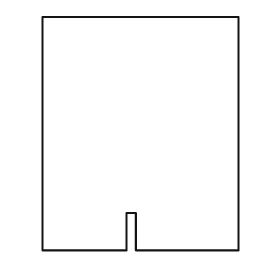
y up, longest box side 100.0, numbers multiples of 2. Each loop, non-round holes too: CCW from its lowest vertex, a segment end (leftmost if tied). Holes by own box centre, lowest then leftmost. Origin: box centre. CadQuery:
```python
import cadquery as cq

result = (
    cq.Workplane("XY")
    .moveTo(-42.0, -50.0)
    .lineTo(-6.0, -50.0)
    .lineTo(-6.0, -34.0)
    .lineTo(-2.0, -34.0)
    .lineTo(-2.0, -50.0)
    .lineTo(42.0, -50.0)
    .lineTo(42.0, 50.0)
    .lineTo(-42.0, 50.0)
    .close()
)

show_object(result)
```